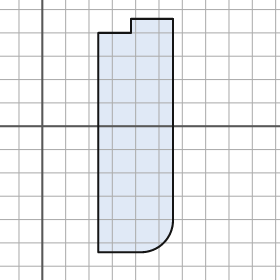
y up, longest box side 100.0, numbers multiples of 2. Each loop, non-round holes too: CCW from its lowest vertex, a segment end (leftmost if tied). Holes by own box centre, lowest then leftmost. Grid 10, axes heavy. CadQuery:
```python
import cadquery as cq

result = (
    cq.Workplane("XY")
    .moveTo(24.0, -54.0)
    .lineTo(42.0, -54.0)
    .threePointArc((52.0, -50.0), (56.0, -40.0))
    .lineTo(56.0, 46.0)
    .lineTo(38.0, 46.0)
    .lineTo(38.0, 40.0)
    .lineTo(24.0, 40.0)
    .close()
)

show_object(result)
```